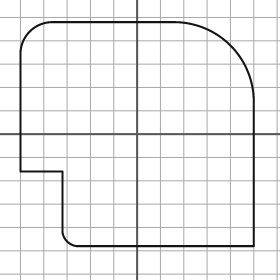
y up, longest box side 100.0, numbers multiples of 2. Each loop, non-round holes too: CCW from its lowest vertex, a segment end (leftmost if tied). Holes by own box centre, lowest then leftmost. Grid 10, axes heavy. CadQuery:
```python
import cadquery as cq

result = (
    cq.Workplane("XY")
    .moveTo(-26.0, -48.0)
    .lineTo(50.0, -48.0)
    .lineTo(50.0, 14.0)
    .threePointArc((40.0, 38.0), (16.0, 48.0))
    .lineTo(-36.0, 48.0)
    .threePointArc((-46.0, 44.0), (-50.0, 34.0))
    .lineTo(-50.0, -16.0)
    .lineTo(-32.0, -16.0)
    .lineTo(-32.0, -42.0)
    .threePointArc((-30.0, -46.0), (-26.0, -48.0))
    .close()
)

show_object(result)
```